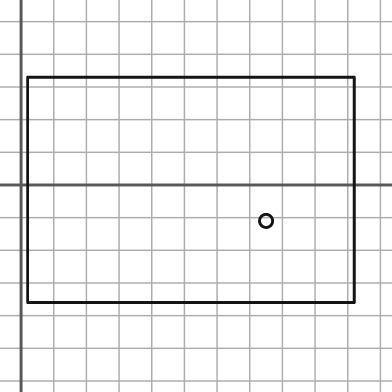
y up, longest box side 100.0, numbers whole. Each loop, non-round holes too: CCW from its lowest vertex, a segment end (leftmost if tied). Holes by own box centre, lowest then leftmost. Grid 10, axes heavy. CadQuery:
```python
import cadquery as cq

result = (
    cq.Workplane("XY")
    .moveTo(2.0, -36.0)
    .lineTo(102.0, -36.0)
    .lineTo(102.0, 33.0)
    .lineTo(2.0, 33.0)
    .close()
    .moveTo(75.0, -11.0)
    .circle(2.0)
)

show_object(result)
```